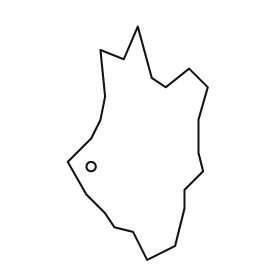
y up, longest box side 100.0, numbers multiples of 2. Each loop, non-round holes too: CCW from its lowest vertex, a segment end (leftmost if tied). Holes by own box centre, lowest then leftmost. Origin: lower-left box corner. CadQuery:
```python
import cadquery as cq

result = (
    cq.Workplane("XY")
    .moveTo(34.0, 0.0)
    .lineTo(46.0, 6.0)
    .lineTo(50.0, 22.0)
    .lineTo(50.0, 30.0)
    .lineTo(58.0, 38.0)
    .lineTo(56.0, 46.0)
    .lineTo(56.0, 60.0)
    .lineTo(60.0, 74.0)
    .lineTo(52.0, 82.0)
    .lineTo(42.0, 74.0)
    .lineTo(36.0, 78.0)
    .lineTo(30.0, 100.0)
    .lineTo(24.0, 86.0)
    .lineTo(14.0, 90.0)
    .lineTo(16.0, 70.0)
    .lineTo(14.0, 60.0)
    .lineTo(10.0, 52.0)
    .lineTo(0.0, 42.0)
    .lineTo(8.0, 28.0)
    .lineTo(16.0, 20.0)
    .lineTo(20.0, 14.0)
    .lineTo(28.0, 12.0)
    .close()
    .moveTo(10.0, 40.0)
    .circle(2.0)
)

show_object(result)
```